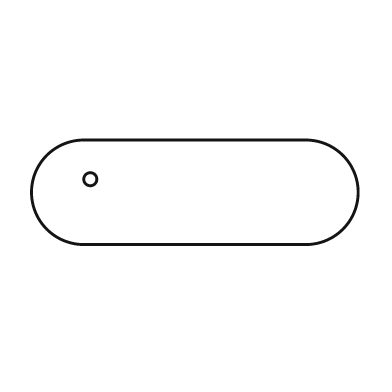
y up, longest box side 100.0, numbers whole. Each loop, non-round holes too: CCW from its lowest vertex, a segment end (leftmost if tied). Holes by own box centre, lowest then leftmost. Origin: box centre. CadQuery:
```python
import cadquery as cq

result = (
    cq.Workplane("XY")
    .moveTo(-34.0, -16.0)
    .lineTo(34.0, -16.0)
    .threePointArc((50.0, 0.0), (34.0, 16.0))
    .lineTo(-34.0, 16.0)
    .threePointArc((-50.0, 0.0), (-34.0, -16.0))
    .close()
    .moveTo(-32.0, 4.0)
    .circle(2.0)
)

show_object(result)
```